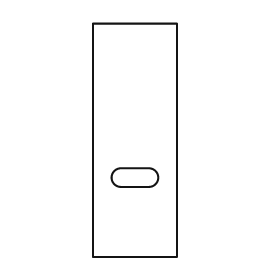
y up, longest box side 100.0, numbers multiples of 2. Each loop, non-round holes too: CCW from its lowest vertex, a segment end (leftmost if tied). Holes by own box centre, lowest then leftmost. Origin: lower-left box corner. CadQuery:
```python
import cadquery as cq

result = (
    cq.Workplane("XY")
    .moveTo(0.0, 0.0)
    .lineTo(36.0, 0.0)
    .lineTo(36.0, 100.0)
    .lineTo(0.0, 100.0)
    .close()
    .moveTo(12.0, 30.0)
    .lineTo(24.0, 30.0)
    .threePointArc((28.0, 34.0), (24.0, 38.0))
    .lineTo(12.0, 38.0)
    .threePointArc((8.0, 34.0), (12.0, 30.0))
    .close()
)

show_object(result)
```